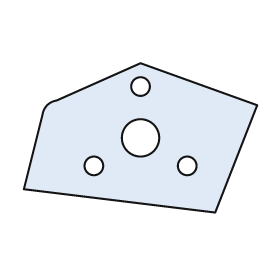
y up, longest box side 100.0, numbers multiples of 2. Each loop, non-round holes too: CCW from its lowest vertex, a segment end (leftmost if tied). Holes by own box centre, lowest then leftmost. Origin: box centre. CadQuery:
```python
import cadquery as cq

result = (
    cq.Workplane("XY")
    .moveTo(32.0, -32.0)
    .lineTo(50.0, 14.0)
    .lineTo(0.0, 32.0)
    .lineTo(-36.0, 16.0)
    .threePointArc((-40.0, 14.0), (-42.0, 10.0))
    .lineTo(-50.0, -22.0)
    .close()
    .moveTo(-20.0, -12.0)
    .circle(4.0)
    .moveTo(20.0, -12.0)
    .circle(4.0)
    .moveTo(0.0, 0.0)
    .circle(8.0)
    .moveTo(0.0, 22.0)
    .circle(4.0)
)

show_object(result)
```